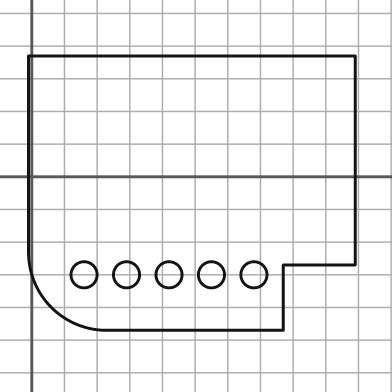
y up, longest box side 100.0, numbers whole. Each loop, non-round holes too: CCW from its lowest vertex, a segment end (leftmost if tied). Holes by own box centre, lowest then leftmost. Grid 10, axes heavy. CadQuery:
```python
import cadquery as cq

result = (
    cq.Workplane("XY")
    .moveTo(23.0, -47.0)
    .lineTo(77.0, -47.0)
    .lineTo(77.0, -27.0)
    .lineTo(99.0, -27.0)
    .lineTo(99.0, 37.0)
    .lineTo(-1.0, 37.0)
    .lineTo(-1.0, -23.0)
    .threePointArc((6.0, -40.0), (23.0, -47.0))
    .close()
    .moveTo(16.0, -30.0)
    .circle(4.0)
    .moveTo(29.0, -30.0)
    .circle(4.0)
    .moveTo(42.0, -30.0)
    .circle(4.0)
    .moveTo(55.0, -30.0)
    .circle(4.0)
    .moveTo(68.0, -30.0)
    .circle(4.0)
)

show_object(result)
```